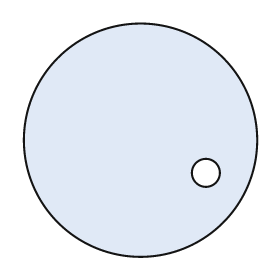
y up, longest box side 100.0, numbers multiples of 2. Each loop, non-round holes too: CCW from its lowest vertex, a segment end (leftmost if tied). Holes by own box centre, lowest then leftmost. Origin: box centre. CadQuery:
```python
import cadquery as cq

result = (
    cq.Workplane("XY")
    .moveTo(0.0, 0.0)
    .circle(50.0)
    .moveTo(28.0, -14.0)
    .circle(6.0)
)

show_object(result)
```